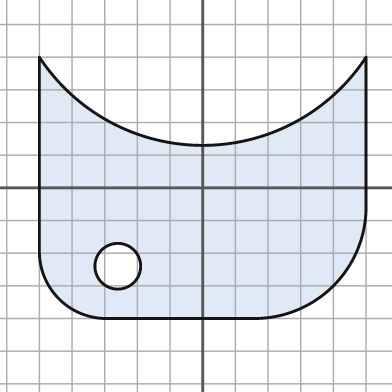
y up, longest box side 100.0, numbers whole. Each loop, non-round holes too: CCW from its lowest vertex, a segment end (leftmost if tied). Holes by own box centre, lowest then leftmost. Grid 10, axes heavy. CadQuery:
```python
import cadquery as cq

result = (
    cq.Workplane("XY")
    .moveTo(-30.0, -40.0)
    .lineTo(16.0, -40.0)
    .threePointArc((40.0, -30.0), (50.0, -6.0))
    .lineTo(50.0, 40.0)
    .threePointArc((0.0, 13.0), (-50.0, 40.0))
    .lineTo(-50.0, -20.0)
    .threePointArc((-44.0, -34.0), (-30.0, -40.0))
    .close()
    .moveTo(-26.0, -24.0)
    .circle(7.0)
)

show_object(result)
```